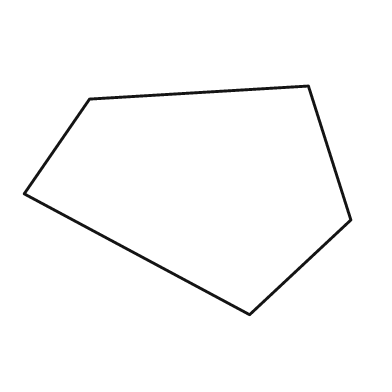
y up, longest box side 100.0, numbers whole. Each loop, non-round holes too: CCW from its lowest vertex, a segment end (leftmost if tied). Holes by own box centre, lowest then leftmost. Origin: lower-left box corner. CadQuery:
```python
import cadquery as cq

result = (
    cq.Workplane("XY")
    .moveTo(69.0, 0.0)
    .lineTo(100.0, 29.0)
    .lineTo(87.0, 70.0)
    .lineTo(20.0, 66.0)
    .lineTo(0.0, 37.0)
    .close()
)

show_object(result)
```